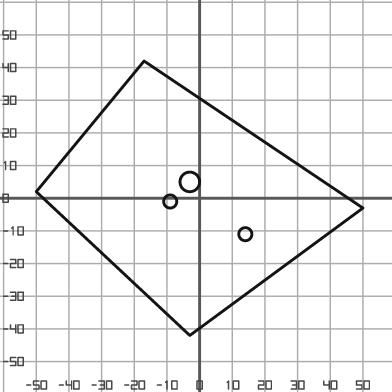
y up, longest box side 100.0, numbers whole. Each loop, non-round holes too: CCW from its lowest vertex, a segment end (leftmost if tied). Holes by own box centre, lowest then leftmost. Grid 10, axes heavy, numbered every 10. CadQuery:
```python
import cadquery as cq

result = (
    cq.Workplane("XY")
    .moveTo(-3.0, -42.0)
    .lineTo(50.0, -3.0)
    .lineTo(-17.0, 42.0)
    .lineTo(-50.0, 2.0)
    .close()
    .moveTo(14.0, -11.0)
    .circle(2.0)
    .moveTo(-9.0, -1.0)
    .circle(2.0)
    .moveTo(-3.0, 5.0)
    .circle(3.0)
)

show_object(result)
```